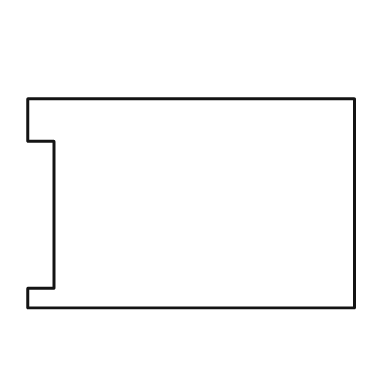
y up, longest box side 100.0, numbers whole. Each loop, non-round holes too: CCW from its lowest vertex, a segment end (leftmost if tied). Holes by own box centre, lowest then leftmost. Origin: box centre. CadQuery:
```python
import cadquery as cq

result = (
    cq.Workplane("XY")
    .moveTo(-50.0, -32.0)
    .lineTo(50.0, -32.0)
    .lineTo(50.0, 32.0)
    .lineTo(-50.0, 32.0)
    .lineTo(-50.0, 19.0)
    .lineTo(-42.0, 19.0)
    .lineTo(-42.0, -26.0)
    .lineTo(-50.0, -26.0)
    .close()
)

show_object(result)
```